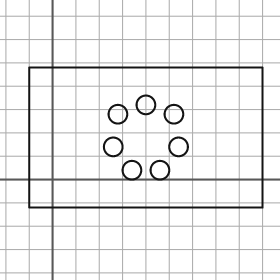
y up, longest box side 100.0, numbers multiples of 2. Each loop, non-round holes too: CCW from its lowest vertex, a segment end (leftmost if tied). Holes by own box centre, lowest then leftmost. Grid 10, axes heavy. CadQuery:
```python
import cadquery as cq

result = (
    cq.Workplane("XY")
    .moveTo(-10.0, -12.0)
    .lineTo(90.0, -12.0)
    .lineTo(90.0, 48.0)
    .lineTo(-10.0, 48.0)
    .close()
    .moveTo(34.0, 4.0)
    .circle(4.0)
    .moveTo(46.0, 4.0)
    .circle(4.0)
    .moveTo(26.0, 14.0)
    .circle(4.0)
    .moveTo(54.0, 14.0)
    .circle(4.0)
    .moveTo(28.0, 28.0)
    .circle(4.0)
    .moveTo(52.0, 28.0)
    .circle(4.0)
    .moveTo(40.0, 32.0)
    .circle(4.0)
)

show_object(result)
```